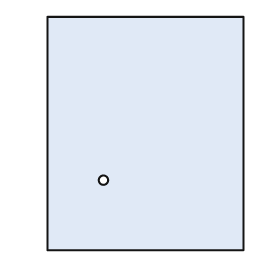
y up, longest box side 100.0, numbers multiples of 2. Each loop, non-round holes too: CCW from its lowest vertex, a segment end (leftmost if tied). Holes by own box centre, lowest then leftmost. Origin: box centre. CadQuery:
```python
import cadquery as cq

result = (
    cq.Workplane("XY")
    .moveTo(-42.0, -50.0)
    .lineTo(42.0, -50.0)
    .lineTo(42.0, 50.0)
    .lineTo(-42.0, 50.0)
    .close()
    .moveTo(-18.0, -20.0)
    .circle(2.0)
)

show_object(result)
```